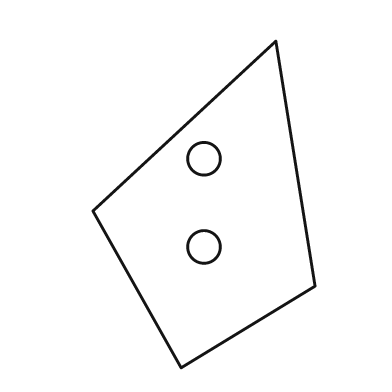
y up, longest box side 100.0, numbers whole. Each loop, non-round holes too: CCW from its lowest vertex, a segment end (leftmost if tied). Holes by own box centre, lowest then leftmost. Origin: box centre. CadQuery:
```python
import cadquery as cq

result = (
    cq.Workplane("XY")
    .moveTo(-7.0, -50.0)
    .lineTo(34.0, -25.0)
    .lineTo(22.0, 50.0)
    .lineTo(-34.0, -2.0)
    .close()
    .moveTo(0.0, -13.0)
    .circle(5.0)
    .moveTo(0.0, 14.0)
    .circle(5.0)
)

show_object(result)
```